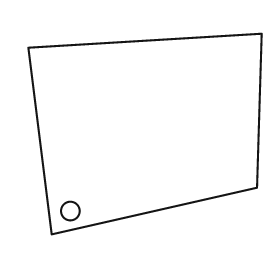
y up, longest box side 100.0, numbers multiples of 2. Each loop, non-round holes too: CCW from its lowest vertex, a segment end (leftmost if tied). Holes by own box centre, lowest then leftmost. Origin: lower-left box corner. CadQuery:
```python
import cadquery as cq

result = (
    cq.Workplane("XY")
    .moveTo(10.0, 0.0)
    .lineTo(98.0, 20.0)
    .lineTo(100.0, 86.0)
    .lineTo(0.0, 80.0)
    .close()
    .moveTo(18.0, 10.0)
    .circle(4.0)
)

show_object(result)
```